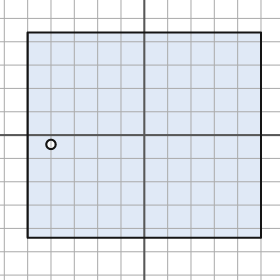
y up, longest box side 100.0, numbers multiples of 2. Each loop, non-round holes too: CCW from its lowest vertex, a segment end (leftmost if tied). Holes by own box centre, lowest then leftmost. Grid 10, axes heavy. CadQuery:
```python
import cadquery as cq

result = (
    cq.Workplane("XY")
    .moveTo(-50.0, -44.0)
    .lineTo(50.0, -44.0)
    .lineTo(50.0, 44.0)
    .lineTo(-50.0, 44.0)
    .close()
    .moveTo(-40.0, -4.0)
    .circle(2.0)
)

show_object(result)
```